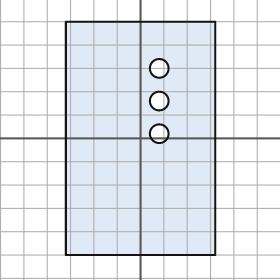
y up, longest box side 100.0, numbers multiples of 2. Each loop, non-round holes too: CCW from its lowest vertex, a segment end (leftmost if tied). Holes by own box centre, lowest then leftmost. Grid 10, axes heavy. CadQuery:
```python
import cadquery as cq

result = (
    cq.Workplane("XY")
    .moveTo(-32.0, -50.0)
    .lineTo(32.0, -50.0)
    .lineTo(32.0, 50.0)
    .lineTo(-32.0, 50.0)
    .close()
    .moveTo(8.0, 2.0)
    .circle(4.0)
    .moveTo(8.0, 16.0)
    .circle(4.0)
    .moveTo(8.0, 30.0)
    .circle(4.0)
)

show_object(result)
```